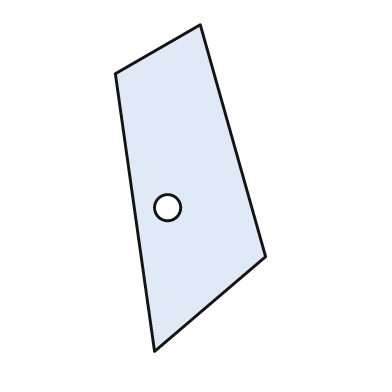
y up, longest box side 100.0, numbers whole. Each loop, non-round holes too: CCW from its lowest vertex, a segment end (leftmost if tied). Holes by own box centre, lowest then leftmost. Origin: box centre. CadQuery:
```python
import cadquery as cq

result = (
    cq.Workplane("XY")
    .moveTo(-11.0, -50.0)
    .lineTo(23.0, -21.0)
    .lineTo(3.0, 50.0)
    .lineTo(-23.0, 35.0)
    .close()
    .moveTo(-7.0, -6.0)
    .circle(4.0)
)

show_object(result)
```